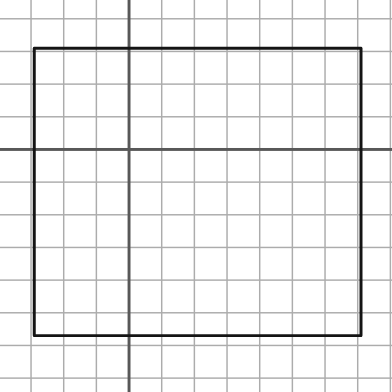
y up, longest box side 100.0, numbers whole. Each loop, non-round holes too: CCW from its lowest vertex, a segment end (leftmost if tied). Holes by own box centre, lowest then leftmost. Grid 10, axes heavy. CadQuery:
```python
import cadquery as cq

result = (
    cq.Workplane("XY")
    .moveTo(-29.0, -57.0)
    .lineTo(71.0, -57.0)
    .lineTo(71.0, 31.0)
    .lineTo(-29.0, 31.0)
    .close()
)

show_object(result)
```